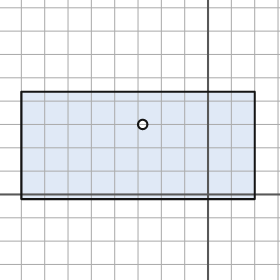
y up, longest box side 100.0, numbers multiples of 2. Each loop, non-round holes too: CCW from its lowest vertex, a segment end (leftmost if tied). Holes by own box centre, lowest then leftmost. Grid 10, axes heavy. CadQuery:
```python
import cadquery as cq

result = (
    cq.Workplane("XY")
    .moveTo(-80.0, -2.0)
    .lineTo(20.0, -2.0)
    .lineTo(20.0, 44.0)
    .lineTo(-80.0, 44.0)
    .close()
    .moveTo(-28.0, 30.0)
    .circle(2.0)
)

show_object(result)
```